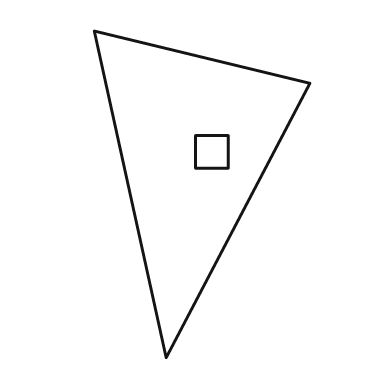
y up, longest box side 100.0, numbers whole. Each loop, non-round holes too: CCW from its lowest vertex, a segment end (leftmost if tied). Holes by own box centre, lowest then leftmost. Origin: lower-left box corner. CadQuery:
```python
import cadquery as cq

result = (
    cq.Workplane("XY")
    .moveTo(22.0, 0.0)
    .lineTo(66.0, 84.0)
    .lineTo(0.0, 100.0)
    .close()
    .moveTo(31.0, 58.0)
    .lineTo(41.0, 58.0)
    .lineTo(41.0, 68.0)
    .lineTo(31.0, 68.0)
    .close()
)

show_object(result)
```